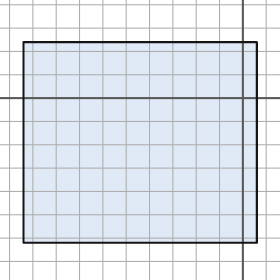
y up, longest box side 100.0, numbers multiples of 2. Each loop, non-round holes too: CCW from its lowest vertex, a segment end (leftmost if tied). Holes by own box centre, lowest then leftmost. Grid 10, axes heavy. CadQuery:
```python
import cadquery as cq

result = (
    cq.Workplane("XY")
    .moveTo(-94.0, -62.0)
    .lineTo(6.0, -62.0)
    .lineTo(6.0, 24.0)
    .lineTo(-94.0, 24.0)
    .close()
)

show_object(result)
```